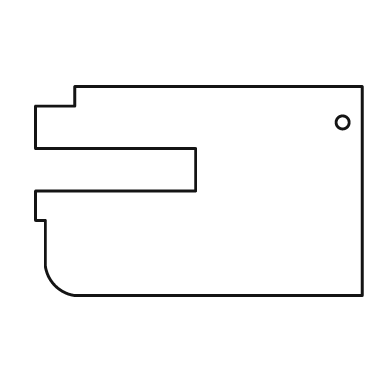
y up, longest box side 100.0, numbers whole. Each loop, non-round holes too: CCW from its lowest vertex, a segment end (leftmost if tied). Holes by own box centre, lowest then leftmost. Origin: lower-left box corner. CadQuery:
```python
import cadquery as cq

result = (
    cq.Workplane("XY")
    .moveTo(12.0, 0.0)
    .lineTo(100.0, 0.0)
    .lineTo(100.0, 64.0)
    .lineTo(12.0, 64.0)
    .lineTo(12.0, 58.0)
    .lineTo(0.0, 58.0)
    .lineTo(0.0, 45.0)
    .lineTo(49.0, 45.0)
    .lineTo(49.0, 32.0)
    .lineTo(0.0, 32.0)
    .lineTo(0.0, 23.0)
    .lineTo(3.0, 23.0)
    .lineTo(3.0, 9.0)
    .threePointArc((6.0, 3.0), (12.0, 0.0))
    .close()
    .moveTo(94.0, 53.0)
    .circle(2.0)
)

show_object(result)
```